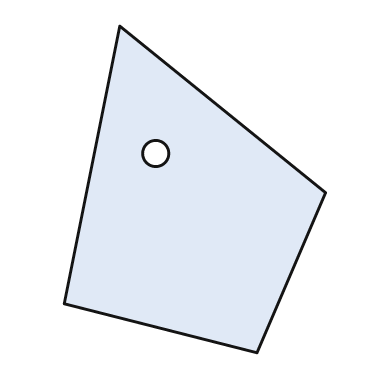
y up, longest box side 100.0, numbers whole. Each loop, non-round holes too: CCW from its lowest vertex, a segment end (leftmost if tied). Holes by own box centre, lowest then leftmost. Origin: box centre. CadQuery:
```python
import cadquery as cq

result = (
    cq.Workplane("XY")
    .moveTo(19.0, -50.0)
    .lineTo(40.0, -1.0)
    .lineTo(-23.0, 50.0)
    .lineTo(-40.0, -35.0)
    .close()
    .moveTo(-12.0, 11.0)
    .circle(4.0)
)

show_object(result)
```